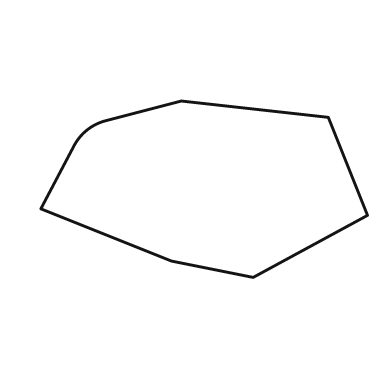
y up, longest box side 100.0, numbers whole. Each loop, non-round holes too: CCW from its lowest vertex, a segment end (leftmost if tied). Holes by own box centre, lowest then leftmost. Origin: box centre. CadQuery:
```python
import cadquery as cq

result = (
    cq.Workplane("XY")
    .moveTo(15.0, -27.0)
    .lineTo(50.0, -8.0)
    .lineTo(38.0, 22.0)
    .lineTo(-7.0, 27.0)
    .lineTo(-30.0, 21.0)
    .threePointArc((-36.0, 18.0), (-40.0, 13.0))
    .lineTo(-50.0, -6.0)
    .lineTo(-10.0, -22.0)
    .close()
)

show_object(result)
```